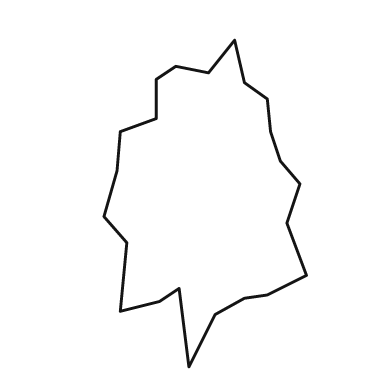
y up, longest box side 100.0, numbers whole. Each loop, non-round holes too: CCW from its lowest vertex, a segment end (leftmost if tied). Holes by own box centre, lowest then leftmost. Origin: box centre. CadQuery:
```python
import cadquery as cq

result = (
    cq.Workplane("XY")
    .moveTo(-5.0, -50.0)
    .lineTo(3.0, -34.0)
    .lineTo(12.0, -29.0)
    .lineTo(19.0, -28.0)
    .lineTo(31.0, -22.0)
    .lineTo(25.0, -6.0)
    .lineTo(29.0, 6.0)
    .lineTo(23.0, 13.0)
    .lineTo(20.0, 22.0)
    .lineTo(19.0, 32.0)
    .lineTo(12.0, 37.0)
    .lineTo(9.0, 50.0)
    .lineTo(1.0, 40.0)
    .lineTo(-9.0, 42.0)
    .lineTo(-15.0, 38.0)
    .lineTo(-15.0, 26.0)
    .lineTo(-26.0, 22.0)
    .lineTo(-27.0, 10.0)
    .lineTo(-31.0, -4.0)
    .lineTo(-24.0, -12.0)
    .lineTo(-26.0, -33.0)
    .lineTo(-14.0, -30.0)
    .lineTo(-8.0, -26.0)
    .close()
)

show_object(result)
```